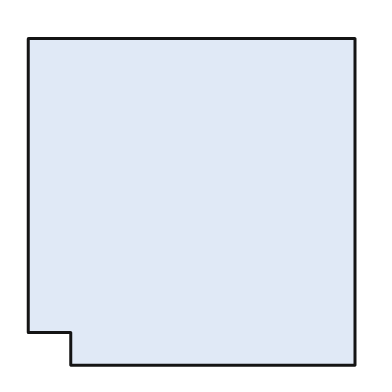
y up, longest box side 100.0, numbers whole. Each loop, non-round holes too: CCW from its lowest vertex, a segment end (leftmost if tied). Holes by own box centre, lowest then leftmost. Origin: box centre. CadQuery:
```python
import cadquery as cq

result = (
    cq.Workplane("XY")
    .moveTo(-37.0, -50.0)
    .lineTo(50.0, -50.0)
    .lineTo(50.0, 50.0)
    .lineTo(-50.0, 50.0)
    .lineTo(-50.0, -40.0)
    .lineTo(-37.0, -40.0)
    .close()
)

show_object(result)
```